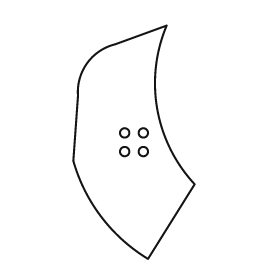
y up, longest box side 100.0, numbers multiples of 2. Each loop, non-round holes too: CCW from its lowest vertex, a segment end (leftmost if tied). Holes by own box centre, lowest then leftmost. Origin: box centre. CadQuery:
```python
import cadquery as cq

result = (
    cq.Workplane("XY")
    .moveTo(6.0, -50.0)
    .lineTo(26.0, -18.0)
    .threePointArc((10.0, 14.0), (14.0, 50.0))
    .lineTo(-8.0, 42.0)
    .threePointArc((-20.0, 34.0), (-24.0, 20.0))
    .lineTo(-26.0, -8.0)
    .threePointArc((-14.0, -32.0), (6.0, -50.0))
    .close()
    .moveTo(-4.0, -4.0)
    .circle(2.0)
    .moveTo(4.0, -4.0)
    .circle(2.0)
    .moveTo(-4.0, 4.0)
    .circle(2.0)
    .moveTo(4.0, 4.0)
    .circle(2.0)
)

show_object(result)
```